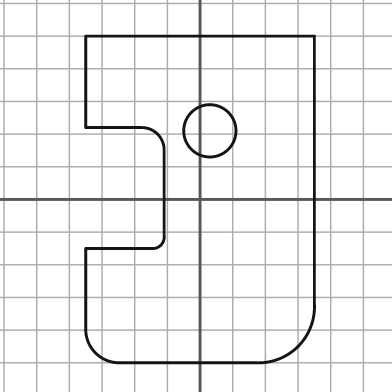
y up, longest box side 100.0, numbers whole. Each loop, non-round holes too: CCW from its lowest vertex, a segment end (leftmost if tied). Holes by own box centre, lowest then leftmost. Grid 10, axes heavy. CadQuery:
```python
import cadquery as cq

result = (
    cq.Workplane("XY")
    .moveTo(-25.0, -50.0)
    .lineTo(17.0, -50.0)
    .threePointArc((30.0, -45.0), (35.0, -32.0))
    .lineTo(35.0, 50.0)
    .lineTo(-35.0, 50.0)
    .lineTo(-35.0, 22.0)
    .lineTo(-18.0, 22.0)
    .threePointArc((-13.0, 20.0), (-11.0, 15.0))
    .lineTo(-11.0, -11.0)
    .threePointArc((-12.0, -14.0), (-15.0, -15.0))
    .lineTo(-35.0, -15.0)
    .lineTo(-35.0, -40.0)
    .threePointArc((-32.0, -47.0), (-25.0, -50.0))
    .close()
    .moveTo(3.0, 21.0)
    .circle(8.0)
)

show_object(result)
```